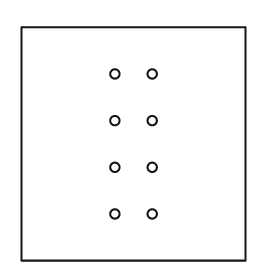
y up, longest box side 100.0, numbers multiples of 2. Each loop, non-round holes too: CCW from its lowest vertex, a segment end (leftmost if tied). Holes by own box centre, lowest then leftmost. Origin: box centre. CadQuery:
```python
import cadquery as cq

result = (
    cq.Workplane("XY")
    .moveTo(-48.0, -50.0)
    .lineTo(48.0, -50.0)
    .lineTo(48.0, 50.0)
    .lineTo(-48.0, 50.0)
    .close()
    .moveTo(-8.0, -30.0)
    .circle(2.0)
    .moveTo(8.0, -30.0)
    .circle(2.0)
    .moveTo(-8.0, -10.0)
    .circle(2.0)
    .moveTo(8.0, -10.0)
    .circle(2.0)
    .moveTo(-8.0, 10.0)
    .circle(2.0)
    .moveTo(8.0, 10.0)
    .circle(2.0)
    .moveTo(-8.0, 30.0)
    .circle(2.0)
    .moveTo(8.0, 30.0)
    .circle(2.0)
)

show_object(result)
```